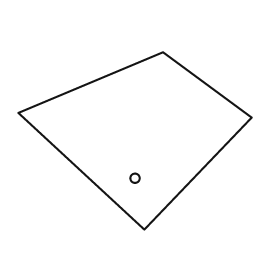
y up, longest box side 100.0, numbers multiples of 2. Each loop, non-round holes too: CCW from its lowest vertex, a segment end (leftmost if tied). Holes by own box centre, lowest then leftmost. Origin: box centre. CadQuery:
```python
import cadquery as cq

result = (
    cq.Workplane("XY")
    .moveTo(4.0, -38.0)
    .lineTo(50.0, 10.0)
    .lineTo(12.0, 38.0)
    .lineTo(-50.0, 12.0)
    .close()
    .moveTo(0.0, -16.0)
    .circle(2.0)
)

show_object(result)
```